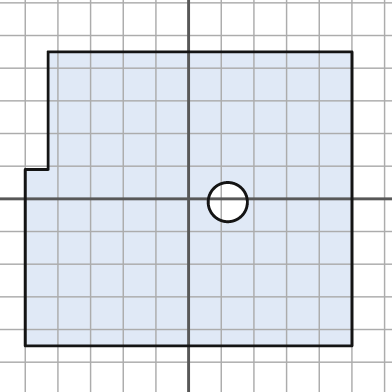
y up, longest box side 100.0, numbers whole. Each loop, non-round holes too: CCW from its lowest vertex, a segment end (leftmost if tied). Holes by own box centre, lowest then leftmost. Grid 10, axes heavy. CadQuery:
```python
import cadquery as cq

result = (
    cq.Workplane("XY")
    .moveTo(-50.0, -45.0)
    .lineTo(50.0, -45.0)
    .lineTo(50.0, 45.0)
    .lineTo(-43.0, 45.0)
    .lineTo(-43.0, 9.0)
    .lineTo(-50.0, 9.0)
    .close()
    .moveTo(12.0, -1.0)
    .circle(6.0)
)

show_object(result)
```